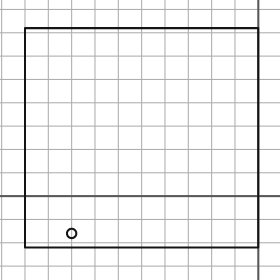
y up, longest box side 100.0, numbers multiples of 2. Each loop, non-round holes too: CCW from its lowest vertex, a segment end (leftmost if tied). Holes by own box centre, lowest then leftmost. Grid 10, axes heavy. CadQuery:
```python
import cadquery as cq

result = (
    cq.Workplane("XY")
    .moveTo(-100.0, -22.0)
    .lineTo(0.0, -22.0)
    .lineTo(0.0, 72.0)
    .lineTo(-100.0, 72.0)
    .close()
    .moveTo(-80.0, -16.0)
    .circle(2.0)
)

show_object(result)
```